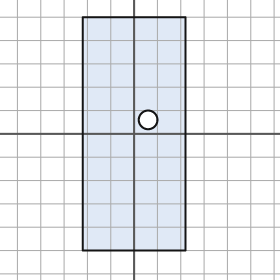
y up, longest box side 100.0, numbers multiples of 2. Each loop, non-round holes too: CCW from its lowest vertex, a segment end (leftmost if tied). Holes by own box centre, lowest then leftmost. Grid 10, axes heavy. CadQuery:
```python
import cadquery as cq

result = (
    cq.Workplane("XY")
    .moveTo(-22.0, -50.0)
    .lineTo(22.0, -50.0)
    .lineTo(22.0, 50.0)
    .lineTo(-22.0, 50.0)
    .close()
    .moveTo(6.0, 6.0)
    .circle(4.0)
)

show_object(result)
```